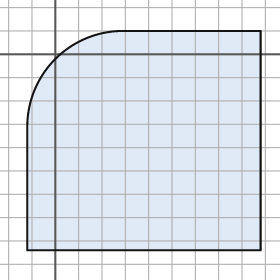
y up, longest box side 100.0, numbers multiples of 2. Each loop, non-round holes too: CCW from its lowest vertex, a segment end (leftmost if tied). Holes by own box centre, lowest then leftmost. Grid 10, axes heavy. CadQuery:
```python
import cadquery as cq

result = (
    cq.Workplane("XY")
    .moveTo(-12.0, -84.0)
    .lineTo(88.0, -84.0)
    .lineTo(88.0, 10.0)
    .lineTo(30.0, 10.0)
    .threePointArc((0.0, -2.0), (-12.0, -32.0))
    .close()
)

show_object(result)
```